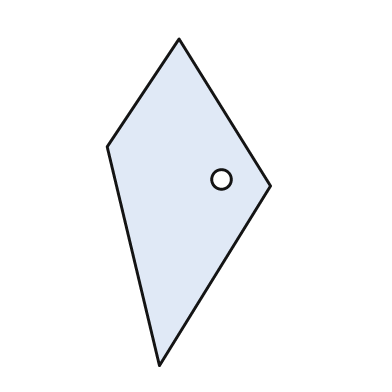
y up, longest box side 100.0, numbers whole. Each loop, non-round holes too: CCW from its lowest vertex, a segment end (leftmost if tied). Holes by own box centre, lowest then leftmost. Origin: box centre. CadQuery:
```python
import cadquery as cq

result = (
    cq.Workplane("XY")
    .moveTo(-9.0, -50.0)
    .lineTo(25.0, 5.0)
    .lineTo(-3.0, 50.0)
    .lineTo(-25.0, 17.0)
    .close()
    .moveTo(10.0, 7.0)
    .circle(3.0)
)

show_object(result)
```